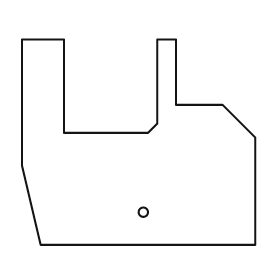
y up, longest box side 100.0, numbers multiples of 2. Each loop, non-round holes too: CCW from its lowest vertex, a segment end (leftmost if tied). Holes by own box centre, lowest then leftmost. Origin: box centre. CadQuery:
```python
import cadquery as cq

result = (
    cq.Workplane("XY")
    .moveTo(-42.0, -44.0)
    .lineTo(50.0, -44.0)
    .lineTo(50.0, 2.0)
    .lineTo(36.0, 16.0)
    .lineTo(16.0, 16.0)
    .lineTo(16.0, 44.0)
    .lineTo(8.0, 44.0)
    .lineTo(8.0, 8.0)
    .lineTo(4.0, 4.0)
    .lineTo(-32.0, 4.0)
    .lineTo(-32.0, 44.0)
    .lineTo(-50.0, 44.0)
    .lineTo(-50.0, -10.0)
    .close()
    .moveTo(2.0, -30.0)
    .circle(2.0)
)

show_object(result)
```